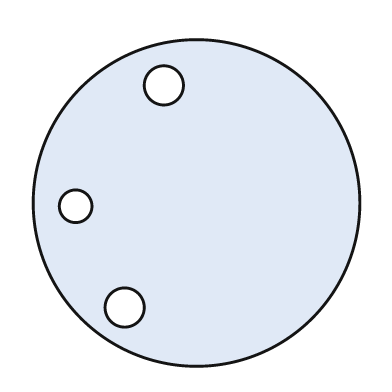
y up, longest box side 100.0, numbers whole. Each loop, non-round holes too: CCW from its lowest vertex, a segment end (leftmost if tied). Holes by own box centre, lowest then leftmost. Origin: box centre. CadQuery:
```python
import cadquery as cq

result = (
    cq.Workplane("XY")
    .moveTo(0.0, 0.0)
    .circle(50.0)
    .moveTo(-22.0, -32.0)
    .circle(6.0)
    .moveTo(-37.0, -1.0)
    .circle(5.0)
    .moveTo(-10.0, 36.0)
    .circle(6.0)
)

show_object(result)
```